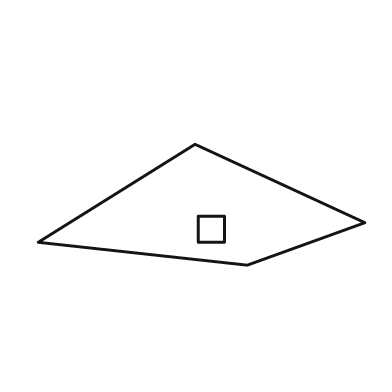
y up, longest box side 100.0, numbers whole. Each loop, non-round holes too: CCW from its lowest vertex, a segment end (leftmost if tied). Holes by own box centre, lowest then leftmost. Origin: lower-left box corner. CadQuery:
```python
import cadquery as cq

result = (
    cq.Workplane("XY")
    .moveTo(64.0, 0.0)
    .lineTo(100.0, 13.0)
    .lineTo(48.0, 37.0)
    .lineTo(0.0, 7.0)
    .close()
    .moveTo(49.0, 7.0)
    .lineTo(57.0, 7.0)
    .lineTo(57.0, 15.0)
    .lineTo(49.0, 15.0)
    .close()
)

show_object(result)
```